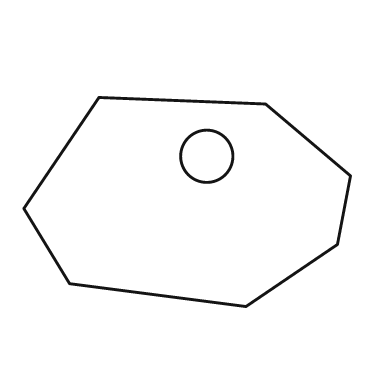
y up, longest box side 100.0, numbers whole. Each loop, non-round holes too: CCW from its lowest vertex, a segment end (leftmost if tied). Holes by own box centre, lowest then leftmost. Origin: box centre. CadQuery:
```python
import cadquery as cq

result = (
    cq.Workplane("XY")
    .moveTo(18.0, -32.0)
    .lineTo(46.0, -13.0)
    .lineTo(50.0, 8.0)
    .lineTo(24.0, 30.0)
    .lineTo(-27.0, 32.0)
    .lineTo(-50.0, -2.0)
    .lineTo(-36.0, -25.0)
    .close()
    .moveTo(6.0, 14.0)
    .circle(8.0)
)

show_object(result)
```